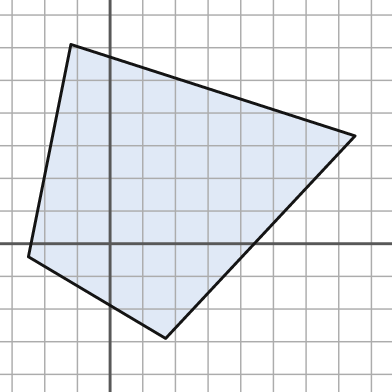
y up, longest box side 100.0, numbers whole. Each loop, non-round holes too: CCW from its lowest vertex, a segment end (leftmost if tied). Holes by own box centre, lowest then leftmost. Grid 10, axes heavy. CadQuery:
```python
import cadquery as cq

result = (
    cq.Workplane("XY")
    .moveTo(17.0, -29.0)
    .lineTo(75.0, 33.0)
    .lineTo(-12.0, 61.0)
    .lineTo(-25.0, -4.0)
    .close()
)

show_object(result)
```